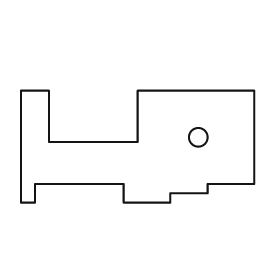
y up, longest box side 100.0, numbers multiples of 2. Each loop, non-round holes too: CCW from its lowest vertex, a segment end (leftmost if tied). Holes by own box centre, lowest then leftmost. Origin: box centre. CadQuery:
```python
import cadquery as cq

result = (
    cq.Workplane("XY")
    .moveTo(-50.0, -24.0)
    .lineTo(-44.0, -24.0)
    .lineTo(-44.0, -16.0)
    .lineTo(-6.0, -16.0)
    .lineTo(-6.0, -24.0)
    .lineTo(14.0, -24.0)
    .lineTo(14.0, -20.0)
    .lineTo(30.0, -20.0)
    .lineTo(30.0, -16.0)
    .lineTo(50.0, -16.0)
    .lineTo(50.0, 24.0)
    .lineTo(0.0, 24.0)
    .lineTo(0.0, 2.0)
    .lineTo(-38.0, 2.0)
    .lineTo(-38.0, 24.0)
    .lineTo(-50.0, 24.0)
    .close()
    .moveTo(26.0, 4.0)
    .circle(4.0)
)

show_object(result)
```